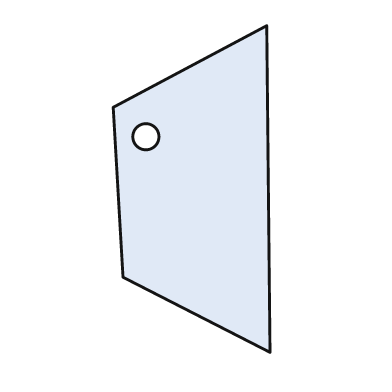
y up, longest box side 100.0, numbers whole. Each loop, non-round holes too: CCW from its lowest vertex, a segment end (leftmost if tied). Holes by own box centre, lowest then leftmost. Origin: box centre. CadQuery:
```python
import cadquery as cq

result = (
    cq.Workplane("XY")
    .moveTo(24.0, -50.0)
    .lineTo(23.0, 50.0)
    .lineTo(-24.0, 25.0)
    .lineTo(-21.0, -27.0)
    .close()
    .moveTo(-14.0, 16.0)
    .circle(4.0)
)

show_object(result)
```